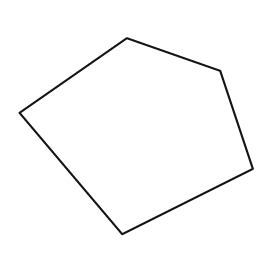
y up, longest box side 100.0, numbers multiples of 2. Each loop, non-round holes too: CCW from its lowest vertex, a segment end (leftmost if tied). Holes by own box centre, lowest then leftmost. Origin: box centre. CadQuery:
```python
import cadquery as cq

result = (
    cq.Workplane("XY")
    .moveTo(-6.0, -42.0)
    .lineTo(50.0, -14.0)
    .lineTo(36.0, 28.0)
    .lineTo(-4.0, 42.0)
    .lineTo(-50.0, 10.0)
    .close()
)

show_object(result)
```